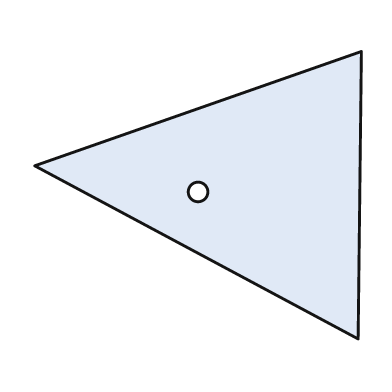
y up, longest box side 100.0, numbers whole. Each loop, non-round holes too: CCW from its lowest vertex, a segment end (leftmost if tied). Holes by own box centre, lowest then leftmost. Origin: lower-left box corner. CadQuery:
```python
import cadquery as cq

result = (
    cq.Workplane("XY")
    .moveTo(99.0, 0.0)
    .lineTo(100.0, 88.0)
    .lineTo(0.0, 53.0)
    .close()
    .moveTo(50.0, 45.0)
    .circle(3.0)
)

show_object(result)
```